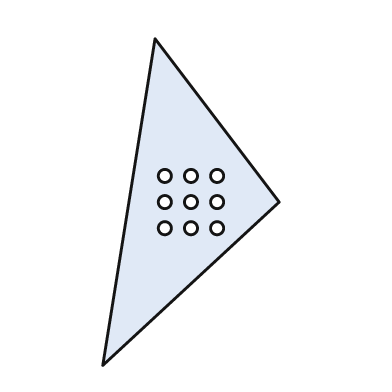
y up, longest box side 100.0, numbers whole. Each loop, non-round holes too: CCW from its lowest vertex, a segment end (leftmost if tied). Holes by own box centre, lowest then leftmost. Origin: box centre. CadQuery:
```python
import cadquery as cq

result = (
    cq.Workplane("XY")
    .moveTo(-27.0, -50.0)
    .lineTo(27.0, 0.0)
    .lineTo(-11.0, 50.0)
    .close()
    .moveTo(-8.0, -8.0)
    .circle(2.0)
    .moveTo(0.0, -8.0)
    .circle(2.0)
    .moveTo(8.0, -8.0)
    .circle(2.0)
    .moveTo(-8.0, 0.0)
    .circle(2.0)
    .moveTo(0.0, 0.0)
    .circle(2.0)
    .moveTo(8.0, 0.0)
    .circle(2.0)
    .moveTo(-8.0, 8.0)
    .circle(2.0)
    .moveTo(0.0, 8.0)
    .circle(2.0)
    .moveTo(8.0, 8.0)
    .circle(2.0)
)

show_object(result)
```